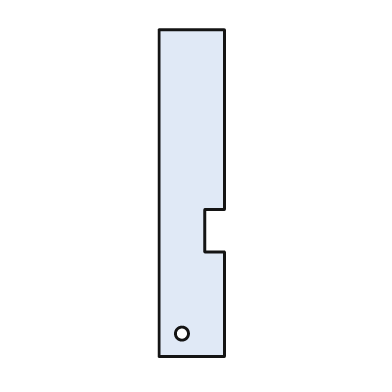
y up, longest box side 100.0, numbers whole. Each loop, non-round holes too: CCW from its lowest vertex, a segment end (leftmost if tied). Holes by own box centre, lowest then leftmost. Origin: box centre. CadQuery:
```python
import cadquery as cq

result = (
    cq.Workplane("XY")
    .moveTo(-10.0, -50.0)
    .lineTo(10.0, -50.0)
    .lineTo(10.0, -18.0)
    .lineTo(4.0, -18.0)
    .lineTo(4.0, -5.0)
    .lineTo(10.0, -5.0)
    .lineTo(10.0, 50.0)
    .lineTo(-10.0, 50.0)
    .close()
    .moveTo(-3.0, -43.0)
    .circle(2.0)
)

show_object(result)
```